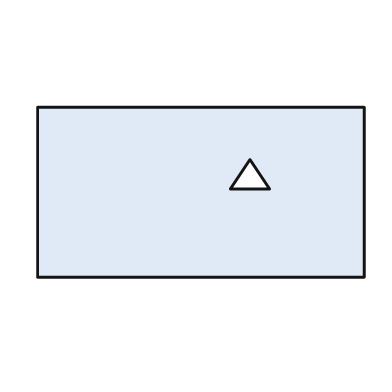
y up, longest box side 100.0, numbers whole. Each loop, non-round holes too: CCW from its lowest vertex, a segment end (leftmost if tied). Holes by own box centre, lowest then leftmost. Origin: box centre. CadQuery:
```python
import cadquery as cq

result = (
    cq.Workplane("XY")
    .moveTo(-50.0, -26.0)
    .lineTo(50.0, -26.0)
    .lineTo(50.0, 26.0)
    .lineTo(-50.0, 26.0)
    .close()
    .moveTo(9.0, 1.0)
    .lineTo(21.0, 1.0)
    .lineTo(15.0, 10.0)
    .close()
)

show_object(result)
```